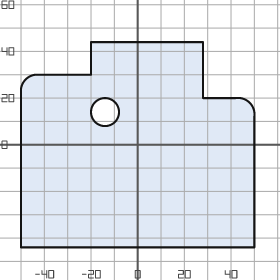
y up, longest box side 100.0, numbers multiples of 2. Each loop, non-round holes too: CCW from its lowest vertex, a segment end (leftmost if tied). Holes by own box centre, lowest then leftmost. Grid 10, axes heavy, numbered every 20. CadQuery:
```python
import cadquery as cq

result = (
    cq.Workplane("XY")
    .moveTo(-50.0, -44.0)
    .lineTo(50.0, -44.0)
    .lineTo(50.0, 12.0)
    .threePointArc((48.0, 18.0), (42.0, 20.0))
    .lineTo(28.0, 20.0)
    .lineTo(28.0, 44.0)
    .lineTo(-20.0, 44.0)
    .lineTo(-20.0, 30.0)
    .lineTo(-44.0, 30.0)
    .threePointArc((-48.0, 28.0), (-50.0, 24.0))
    .close()
    .moveTo(-14.0, 14.0)
    .circle(6.0)
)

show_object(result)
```